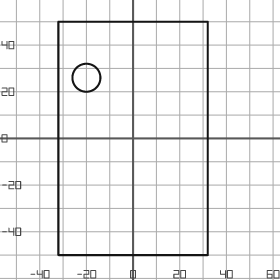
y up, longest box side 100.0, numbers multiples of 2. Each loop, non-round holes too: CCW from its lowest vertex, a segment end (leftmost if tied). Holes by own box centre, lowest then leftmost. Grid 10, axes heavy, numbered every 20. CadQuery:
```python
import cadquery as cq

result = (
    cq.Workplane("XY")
    .moveTo(-32.0, -50.0)
    .lineTo(32.0, -50.0)
    .lineTo(32.0, 50.0)
    .lineTo(-32.0, 50.0)
    .close()
    .moveTo(-20.0, 26.0)
    .circle(6.0)
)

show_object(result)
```